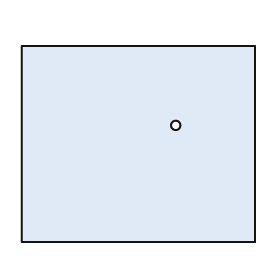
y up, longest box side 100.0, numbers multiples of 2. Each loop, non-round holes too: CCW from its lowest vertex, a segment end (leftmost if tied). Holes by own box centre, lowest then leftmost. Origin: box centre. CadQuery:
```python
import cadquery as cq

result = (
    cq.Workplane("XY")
    .moveTo(-50.0, -42.0)
    .lineTo(50.0, -42.0)
    .lineTo(50.0, 42.0)
    .lineTo(-50.0, 42.0)
    .close()
    .moveTo(16.0, 8.0)
    .circle(2.0)
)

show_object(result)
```